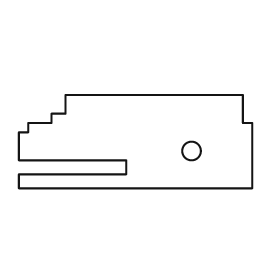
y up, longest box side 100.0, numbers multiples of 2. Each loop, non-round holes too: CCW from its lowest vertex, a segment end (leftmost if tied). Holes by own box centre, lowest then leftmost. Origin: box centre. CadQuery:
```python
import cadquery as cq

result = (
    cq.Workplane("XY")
    .moveTo(-50.0, -20.0)
    .lineTo(50.0, -20.0)
    .lineTo(50.0, 8.0)
    .lineTo(46.0, 8.0)
    .lineTo(46.0, 20.0)
    .lineTo(-30.0, 20.0)
    .lineTo(-30.0, 12.0)
    .lineTo(-36.0, 12.0)
    .lineTo(-36.0, 8.0)
    .lineTo(-46.0, 8.0)
    .lineTo(-46.0, 4.0)
    .lineTo(-50.0, 4.0)
    .lineTo(-50.0, -8.0)
    .lineTo(-4.0, -8.0)
    .lineTo(-4.0, -14.0)
    .lineTo(-50.0, -14.0)
    .close()
    .moveTo(24.0, -4.0)
    .circle(4.0)
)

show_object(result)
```